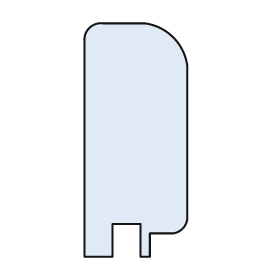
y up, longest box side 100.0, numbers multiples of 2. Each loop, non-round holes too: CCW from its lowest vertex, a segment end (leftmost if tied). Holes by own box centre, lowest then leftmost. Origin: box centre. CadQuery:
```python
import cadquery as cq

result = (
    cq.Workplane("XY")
    .moveTo(-22.0, -50.0)
    .lineTo(-10.0, -50.0)
    .lineTo(-10.0, -36.0)
    .lineTo(2.0, -36.0)
    .lineTo(2.0, -50.0)
    .lineTo(6.0, -50.0)
    .lineTo(6.0, -40.0)
    .lineTo(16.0, -40.0)
    .threePointArc((20.0, -38.0), (22.0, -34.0))
    .lineTo(22.0, 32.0)
    .threePointArc((16.0, 44.0), (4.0, 50.0))
    .lineTo(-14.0, 50.0)
    .threePointArc((-20.0, 48.0), (-22.0, 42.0))
    .close()
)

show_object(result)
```